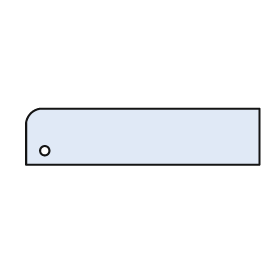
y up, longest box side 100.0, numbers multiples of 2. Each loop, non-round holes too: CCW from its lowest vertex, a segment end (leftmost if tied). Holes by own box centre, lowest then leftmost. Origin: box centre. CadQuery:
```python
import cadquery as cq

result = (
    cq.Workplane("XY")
    .moveTo(-50.0, -12.0)
    .lineTo(50.0, -12.0)
    .lineTo(50.0, 12.0)
    .lineTo(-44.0, 12.0)
    .threePointArc((-48.0, 10.0), (-50.0, 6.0))
    .close()
    .moveTo(-42.0, -6.0)
    .circle(2.0)
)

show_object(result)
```